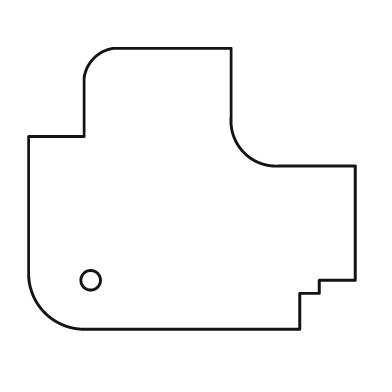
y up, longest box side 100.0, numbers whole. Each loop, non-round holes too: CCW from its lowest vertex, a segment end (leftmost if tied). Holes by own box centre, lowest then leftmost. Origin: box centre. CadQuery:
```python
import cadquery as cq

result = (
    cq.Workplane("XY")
    .moveTo(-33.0, -43.0)
    .lineTo(33.0, -43.0)
    .lineTo(33.0, -32.0)
    .lineTo(39.0, -32.0)
    .lineTo(39.0, -28.0)
    .lineTo(50.0, -28.0)
    .lineTo(50.0, 7.0)
    .lineTo(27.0, 7.0)
    .threePointArc((16.0, 11.0), (12.0, 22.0))
    .lineTo(12.0, 43.0)
    .lineTo(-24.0, 43.0)
    .threePointArc((-30.0, 40.0), (-33.0, 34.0))
    .lineTo(-33.0, 16.0)
    .lineTo(-50.0, 16.0)
    .lineTo(-50.0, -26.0)
    .threePointArc((-45.0, -38.0), (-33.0, -43.0))
    .close()
    .moveTo(-31.0, -28.0)
    .circle(3.0)
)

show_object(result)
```